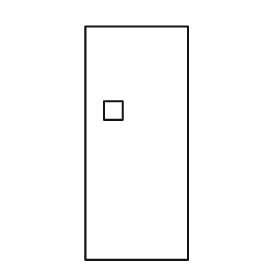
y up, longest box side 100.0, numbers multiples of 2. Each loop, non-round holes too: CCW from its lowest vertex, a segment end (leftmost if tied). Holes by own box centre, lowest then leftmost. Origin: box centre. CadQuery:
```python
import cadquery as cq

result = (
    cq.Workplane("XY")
    .moveTo(-22.0, -50.0)
    .lineTo(22.0, -50.0)
    .lineTo(22.0, 50.0)
    .lineTo(-22.0, 50.0)
    .close()
    .moveTo(-14.0, 10.0)
    .lineTo(-6.0, 10.0)
    .lineTo(-6.0, 18.0)
    .lineTo(-14.0, 18.0)
    .close()
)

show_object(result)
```